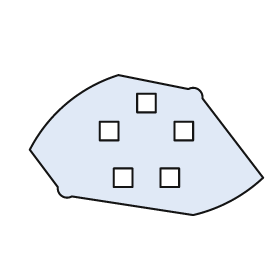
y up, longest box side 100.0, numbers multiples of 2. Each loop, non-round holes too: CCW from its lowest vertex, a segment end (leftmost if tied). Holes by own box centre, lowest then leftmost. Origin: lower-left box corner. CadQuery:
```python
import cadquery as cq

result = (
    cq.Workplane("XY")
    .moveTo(70.0, 0.0)
    .threePointArc((86.0, 6.0), (100.0, 16.0))
    .lineTo(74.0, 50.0)
    .threePointArc((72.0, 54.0), (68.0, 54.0))
    .lineTo(38.0, 60.0)
    .threePointArc((16.0, 48.0), (0.0, 28.0))
    .lineTo(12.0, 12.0)
    .threePointArc((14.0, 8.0), (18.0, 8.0))
    .close()
    .moveTo(36.0, 12.0)
    .lineTo(44.0, 12.0)
    .lineTo(44.0, 20.0)
    .lineTo(36.0, 20.0)
    .close()
    .moveTo(56.0, 12.0)
    .lineTo(64.0, 12.0)
    .lineTo(64.0, 20.0)
    .lineTo(56.0, 20.0)
    .close()
    .moveTo(30.0, 32.0)
    .lineTo(38.0, 32.0)
    .lineTo(38.0, 40.0)
    .lineTo(30.0, 40.0)
    .close()
    .moveTo(62.0, 32.0)
    .lineTo(70.0, 32.0)
    .lineTo(70.0, 40.0)
    .lineTo(62.0, 40.0)
    .close()
    .moveTo(46.0, 44.0)
    .lineTo(54.0, 44.0)
    .lineTo(54.0, 52.0)
    .lineTo(46.0, 52.0)
    .close()
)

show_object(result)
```